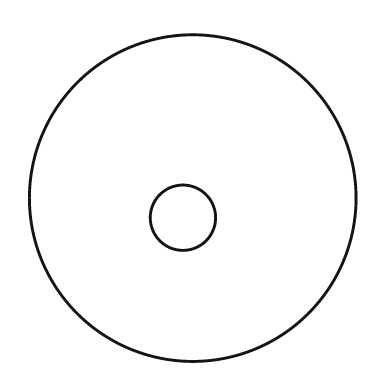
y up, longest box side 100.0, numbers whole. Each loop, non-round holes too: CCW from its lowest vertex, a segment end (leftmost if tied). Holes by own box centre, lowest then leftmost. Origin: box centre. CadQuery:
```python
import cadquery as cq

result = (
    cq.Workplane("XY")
    .moveTo(0.0, 0.0)
    .circle(50.0)
    .moveTo(-3.0, -6.0)
    .circle(10.0)
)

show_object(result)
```